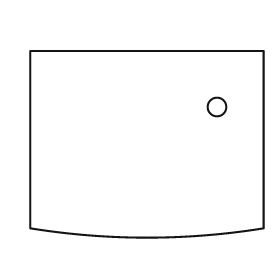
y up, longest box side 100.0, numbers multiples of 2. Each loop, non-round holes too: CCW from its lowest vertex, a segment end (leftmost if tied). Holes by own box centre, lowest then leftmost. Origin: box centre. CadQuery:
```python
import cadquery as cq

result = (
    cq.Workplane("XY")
    .moveTo(-50.0, -36.0)
    .threePointArc((0.0, -40.0), (50.0, -36.0))
    .lineTo(50.0, 40.0)
    .lineTo(-50.0, 40.0)
    .close()
    .moveTo(30.0, 16.0)
    .circle(4.0)
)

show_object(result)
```